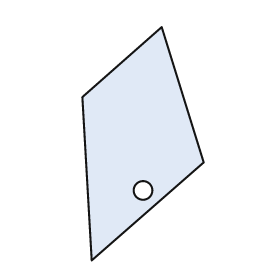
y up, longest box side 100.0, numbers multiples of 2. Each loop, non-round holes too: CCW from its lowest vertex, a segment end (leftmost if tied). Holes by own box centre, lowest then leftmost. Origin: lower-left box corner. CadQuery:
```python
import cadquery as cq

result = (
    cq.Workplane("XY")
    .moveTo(4.0, 0.0)
    .lineTo(52.0, 42.0)
    .lineTo(34.0, 100.0)
    .lineTo(0.0, 70.0)
    .close()
    .moveTo(26.0, 30.0)
    .circle(4.0)
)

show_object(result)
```